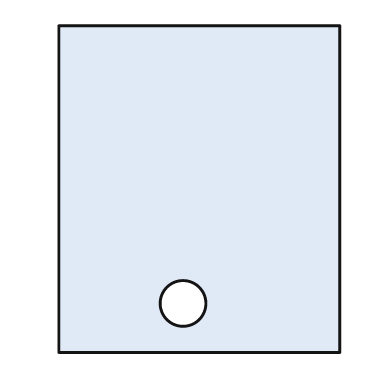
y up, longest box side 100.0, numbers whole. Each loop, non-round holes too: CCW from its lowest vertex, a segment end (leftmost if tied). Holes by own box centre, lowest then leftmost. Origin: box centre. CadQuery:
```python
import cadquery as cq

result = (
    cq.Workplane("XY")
    .moveTo(-43.0, -50.0)
    .lineTo(43.0, -50.0)
    .lineTo(43.0, 50.0)
    .lineTo(-43.0, 50.0)
    .close()
    .moveTo(-5.0, -35.0)
    .circle(7.0)
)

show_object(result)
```